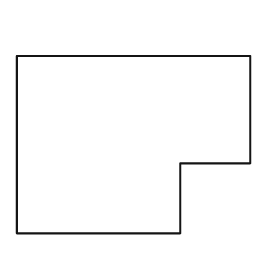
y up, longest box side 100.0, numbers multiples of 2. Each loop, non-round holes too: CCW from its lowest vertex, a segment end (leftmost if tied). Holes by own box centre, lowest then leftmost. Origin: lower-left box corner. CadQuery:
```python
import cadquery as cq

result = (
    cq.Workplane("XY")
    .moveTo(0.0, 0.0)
    .lineTo(70.0, 0.0)
    .lineTo(70.0, 30.0)
    .lineTo(100.0, 30.0)
    .lineTo(100.0, 76.0)
    .lineTo(0.0, 76.0)
    .close()
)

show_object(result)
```